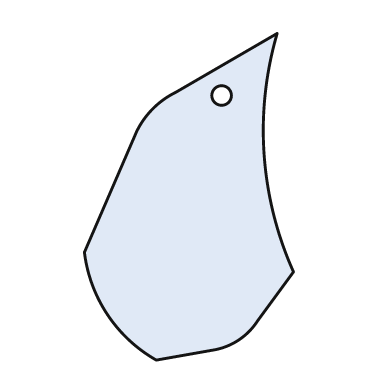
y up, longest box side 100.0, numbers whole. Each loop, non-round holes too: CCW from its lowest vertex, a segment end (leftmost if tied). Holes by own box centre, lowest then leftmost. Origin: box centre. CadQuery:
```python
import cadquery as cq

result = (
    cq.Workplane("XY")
    .moveTo(-10.0, -50.0)
    .lineTo(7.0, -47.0)
    .threePointArc((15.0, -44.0), (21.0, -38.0))
    .lineTo(32.0, -23.0)
    .threePointArc((23.0, 13.0), (27.0, 50.0))
    .lineTo(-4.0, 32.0)
    .threePointArc((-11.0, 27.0), (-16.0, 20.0))
    .lineTo(-32.0, -17.0)
    .threePointArc((-25.0, -36.0), (-10.0, -50.0))
    .close()
    .moveTo(10.0, 31.0)
    .circle(3.0)
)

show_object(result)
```